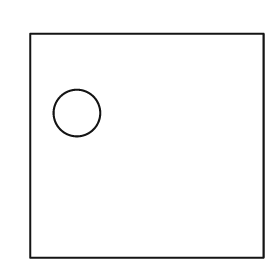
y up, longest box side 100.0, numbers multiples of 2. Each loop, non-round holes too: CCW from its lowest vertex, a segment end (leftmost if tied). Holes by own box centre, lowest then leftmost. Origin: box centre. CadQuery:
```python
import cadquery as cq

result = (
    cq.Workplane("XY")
    .moveTo(-50.0, -48.0)
    .lineTo(50.0, -48.0)
    .lineTo(50.0, 48.0)
    .lineTo(-50.0, 48.0)
    .close()
    .moveTo(-30.0, 14.0)
    .circle(10.0)
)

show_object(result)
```